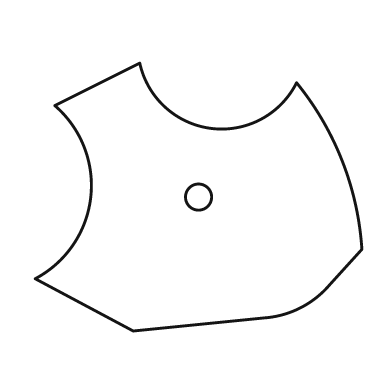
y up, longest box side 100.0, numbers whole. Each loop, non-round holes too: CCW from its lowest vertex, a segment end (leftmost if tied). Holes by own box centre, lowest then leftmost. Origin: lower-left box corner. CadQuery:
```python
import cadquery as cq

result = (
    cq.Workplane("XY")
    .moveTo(30.0, 0.0)
    .lineTo(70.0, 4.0)
    .threePointArc((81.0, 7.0), (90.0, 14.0))
    .lineTo(100.0, 25.0)
    .threePointArc((94.0, 52.0), (80.0, 76.0))
    .threePointArc((54.0, 62.0), (32.0, 82.0))
    .lineTo(6.0, 69.0)
    .threePointArc((17.0, 41.0), (0.0, 16.0))
    .close()
    .moveTo(50.0, 41.0)
    .circle(4.0)
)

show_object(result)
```